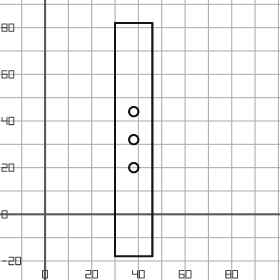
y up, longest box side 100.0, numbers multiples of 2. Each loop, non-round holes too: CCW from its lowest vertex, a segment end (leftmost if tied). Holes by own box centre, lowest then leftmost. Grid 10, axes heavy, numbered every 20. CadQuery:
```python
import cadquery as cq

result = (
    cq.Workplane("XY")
    .moveTo(30.0, -18.0)
    .lineTo(46.0, -18.0)
    .lineTo(46.0, 82.0)
    .lineTo(30.0, 82.0)
    .close()
    .moveTo(38.0, 20.0)
    .circle(2.0)
    .moveTo(38.0, 32.0)
    .circle(2.0)
    .moveTo(38.0, 44.0)
    .circle(2.0)
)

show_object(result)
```